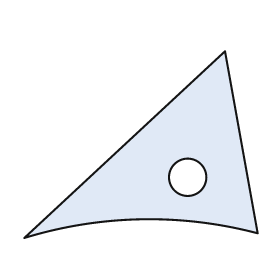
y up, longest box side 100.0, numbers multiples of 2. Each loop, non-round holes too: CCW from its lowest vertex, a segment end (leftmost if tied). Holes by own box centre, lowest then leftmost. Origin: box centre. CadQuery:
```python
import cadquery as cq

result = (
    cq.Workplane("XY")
    .moveTo(-50.0, -40.0)
    .threePointArc((0.0, -32.0), (50.0, -38.0))
    .lineTo(36.0, 40.0)
    .close()
    .moveTo(20.0, -14.0)
    .circle(8.0)
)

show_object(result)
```